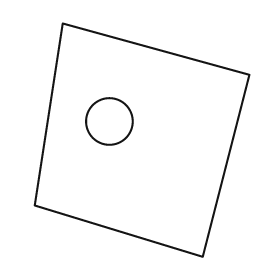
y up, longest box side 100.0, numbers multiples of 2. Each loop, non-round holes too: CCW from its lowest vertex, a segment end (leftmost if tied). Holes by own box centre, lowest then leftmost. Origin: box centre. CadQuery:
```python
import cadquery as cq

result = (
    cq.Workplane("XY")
    .moveTo(26.0, -50.0)
    .lineTo(46.0, 28.0)
    .lineTo(-34.0, 50.0)
    .lineTo(-46.0, -28.0)
    .close()
    .moveTo(-14.0, 8.0)
    .circle(10.0)
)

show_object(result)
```